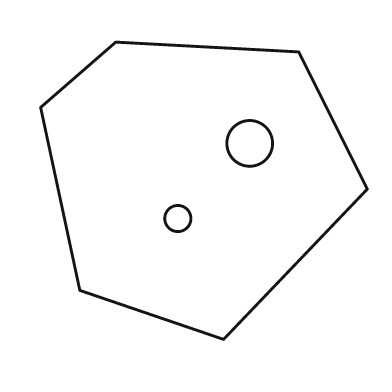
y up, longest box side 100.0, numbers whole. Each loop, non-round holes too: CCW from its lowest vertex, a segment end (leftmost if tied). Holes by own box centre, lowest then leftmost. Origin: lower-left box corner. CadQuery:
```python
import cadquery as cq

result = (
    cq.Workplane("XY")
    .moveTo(56.0, 0.0)
    .lineTo(100.0, 46.0)
    .lineTo(79.0, 88.0)
    .lineTo(23.0, 91.0)
    .lineTo(0.0, 71.0)
    .lineTo(12.0, 15.0)
    .close()
    .moveTo(42.0, 37.0)
    .circle(4.0)
    .moveTo(64.0, 60.0)
    .circle(7.0)
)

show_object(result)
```